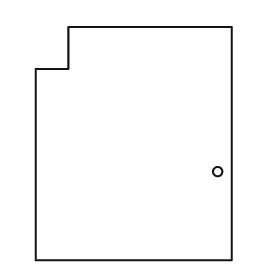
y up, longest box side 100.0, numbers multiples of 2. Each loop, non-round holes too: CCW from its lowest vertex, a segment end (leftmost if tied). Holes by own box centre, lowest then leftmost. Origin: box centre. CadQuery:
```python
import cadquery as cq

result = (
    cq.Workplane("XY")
    .moveTo(-42.0, -50.0)
    .lineTo(42.0, -50.0)
    .lineTo(42.0, 50.0)
    .lineTo(-28.0, 50.0)
    .lineTo(-28.0, 32.0)
    .lineTo(-42.0, 32.0)
    .close()
    .moveTo(36.0, -12.0)
    .circle(2.0)
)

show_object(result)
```